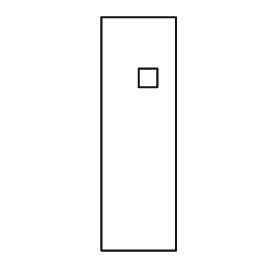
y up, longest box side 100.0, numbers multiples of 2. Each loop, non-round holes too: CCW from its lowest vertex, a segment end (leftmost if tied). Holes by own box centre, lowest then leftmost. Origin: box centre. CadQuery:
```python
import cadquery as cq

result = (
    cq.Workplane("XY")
    .moveTo(-16.0, -50.0)
    .lineTo(16.0, -50.0)
    .lineTo(16.0, 50.0)
    .lineTo(-16.0, 50.0)
    .close()
    .moveTo(0.0, 20.0)
    .lineTo(8.0, 20.0)
    .lineTo(8.0, 28.0)
    .lineTo(0.0, 28.0)
    .close()
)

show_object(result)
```